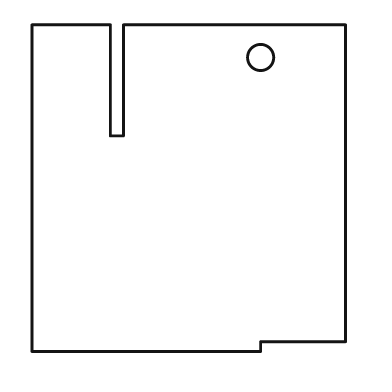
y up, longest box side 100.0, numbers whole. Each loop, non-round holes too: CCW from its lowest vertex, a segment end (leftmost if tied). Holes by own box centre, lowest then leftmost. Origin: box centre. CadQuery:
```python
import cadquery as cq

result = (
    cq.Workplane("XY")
    .moveTo(-48.0, -50.0)
    .lineTo(22.0, -50.0)
    .lineTo(22.0, -47.0)
    .lineTo(48.0, -47.0)
    .lineTo(48.0, 50.0)
    .lineTo(-20.0, 50.0)
    .lineTo(-20.0, 16.0)
    .lineTo(-24.0, 16.0)
    .lineTo(-24.0, 50.0)
    .lineTo(-48.0, 50.0)
    .close()
    .moveTo(22.0, 40.0)
    .circle(4.0)
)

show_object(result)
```